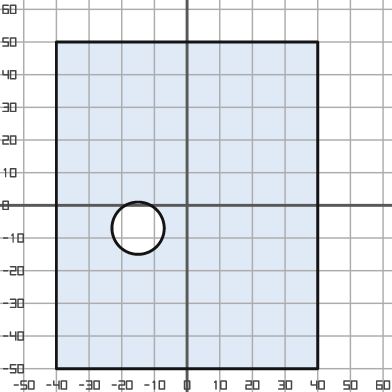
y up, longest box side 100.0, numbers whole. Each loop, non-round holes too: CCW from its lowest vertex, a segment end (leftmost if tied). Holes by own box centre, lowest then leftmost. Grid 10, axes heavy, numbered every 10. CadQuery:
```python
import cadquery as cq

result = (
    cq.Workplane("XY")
    .moveTo(-40.0, -50.0)
    .lineTo(40.0, -50.0)
    .lineTo(40.0, 50.0)
    .lineTo(-40.0, 50.0)
    .close()
    .moveTo(-15.0, -7.0)
    .circle(8.0)
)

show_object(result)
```